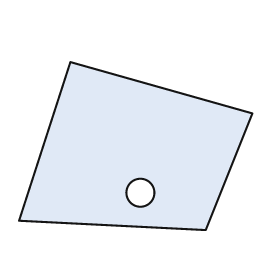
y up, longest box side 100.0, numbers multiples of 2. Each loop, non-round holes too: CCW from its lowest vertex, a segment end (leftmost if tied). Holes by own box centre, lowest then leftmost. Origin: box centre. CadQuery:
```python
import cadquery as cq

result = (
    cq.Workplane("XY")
    .moveTo(30.0, -36.0)
    .lineTo(50.0, 14.0)
    .lineTo(-28.0, 36.0)
    .lineTo(-50.0, -32.0)
    .close()
    .moveTo(2.0, -20.0)
    .circle(6.0)
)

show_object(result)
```